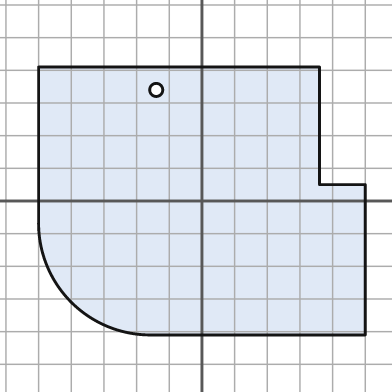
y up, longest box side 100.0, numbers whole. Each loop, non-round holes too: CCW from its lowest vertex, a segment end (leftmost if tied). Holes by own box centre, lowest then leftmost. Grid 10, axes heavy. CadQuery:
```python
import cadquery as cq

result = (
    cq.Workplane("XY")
    .moveTo(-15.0, -41.0)
    .lineTo(50.0, -41.0)
    .lineTo(50.0, 5.0)
    .lineTo(36.0, 5.0)
    .lineTo(36.0, 41.0)
    .lineTo(-50.0, 41.0)
    .lineTo(-50.0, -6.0)
    .threePointArc((-40.0, -31.0), (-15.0, -41.0))
    .close()
    .moveTo(-14.0, 34.0)
    .circle(2.0)
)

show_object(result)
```